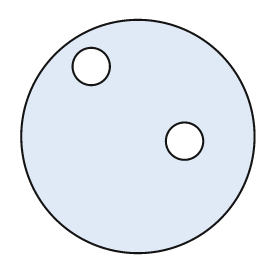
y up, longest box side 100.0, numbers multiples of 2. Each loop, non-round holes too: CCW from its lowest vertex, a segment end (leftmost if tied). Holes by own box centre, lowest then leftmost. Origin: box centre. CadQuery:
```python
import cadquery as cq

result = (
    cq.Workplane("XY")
    .moveTo(0.0, 0.0)
    .circle(50.0)
    .moveTo(20.0, -2.0)
    .circle(8.0)
    .moveTo(-20.0, 30.0)
    .circle(8.0)
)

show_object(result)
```